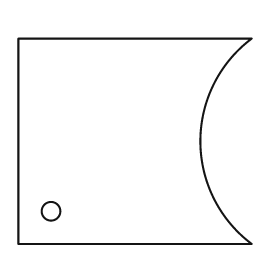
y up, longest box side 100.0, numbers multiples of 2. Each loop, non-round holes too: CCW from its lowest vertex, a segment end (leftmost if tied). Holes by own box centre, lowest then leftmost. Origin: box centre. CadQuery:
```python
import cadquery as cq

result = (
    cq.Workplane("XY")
    .moveTo(-50.0, -44.0)
    .lineTo(50.0, -44.0)
    .threePointArc((28.0, 0.0), (50.0, 44.0))
    .lineTo(-50.0, 44.0)
    .close()
    .moveTo(-36.0, -30.0)
    .circle(4.0)
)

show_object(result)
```